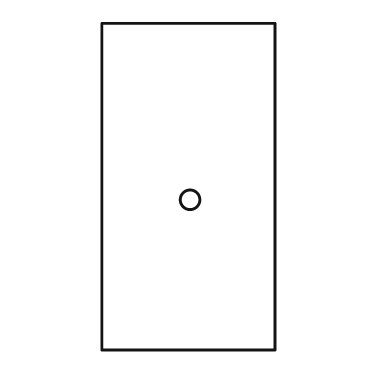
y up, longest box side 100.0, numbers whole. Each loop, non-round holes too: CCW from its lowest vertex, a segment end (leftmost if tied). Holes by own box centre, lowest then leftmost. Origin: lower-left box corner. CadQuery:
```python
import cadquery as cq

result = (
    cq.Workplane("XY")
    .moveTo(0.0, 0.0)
    .lineTo(53.0, 0.0)
    .lineTo(53.0, 100.0)
    .lineTo(0.0, 100.0)
    .close()
    .moveTo(27.0, 46.0)
    .circle(3.0)
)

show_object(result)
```